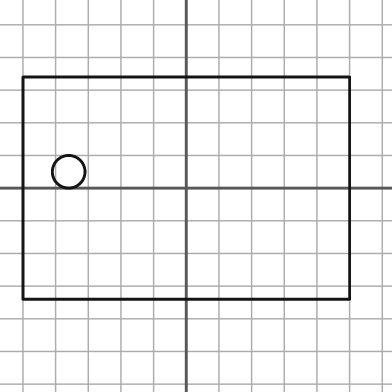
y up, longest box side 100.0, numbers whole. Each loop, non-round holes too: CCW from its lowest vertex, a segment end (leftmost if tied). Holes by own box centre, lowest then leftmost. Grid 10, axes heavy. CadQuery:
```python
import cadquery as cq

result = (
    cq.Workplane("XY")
    .moveTo(-50.0, -34.0)
    .lineTo(50.0, -34.0)
    .lineTo(50.0, 34.0)
    .lineTo(-50.0, 34.0)
    .close()
    .moveTo(-36.0, 5.0)
    .circle(5.0)
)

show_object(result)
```